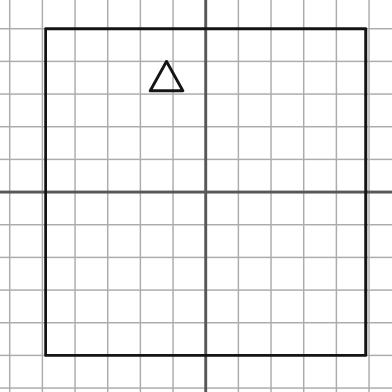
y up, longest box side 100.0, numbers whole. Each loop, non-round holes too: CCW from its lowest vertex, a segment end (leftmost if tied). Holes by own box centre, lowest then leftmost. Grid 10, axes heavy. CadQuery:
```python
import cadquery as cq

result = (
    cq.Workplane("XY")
    .moveTo(-49.0, -50.0)
    .lineTo(49.0, -50.0)
    .lineTo(49.0, 50.0)
    .lineTo(-49.0, 50.0)
    .close()
    .moveTo(-17.0, 31.0)
    .lineTo(-7.0, 31.0)
    .lineTo(-12.0, 40.0)
    .close()
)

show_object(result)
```